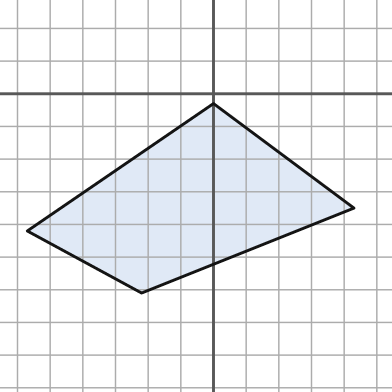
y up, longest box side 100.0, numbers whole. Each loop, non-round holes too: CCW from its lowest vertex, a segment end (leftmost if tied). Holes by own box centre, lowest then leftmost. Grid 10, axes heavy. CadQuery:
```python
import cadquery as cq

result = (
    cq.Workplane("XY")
    .moveTo(-22.0, -61.0)
    .lineTo(43.0, -35.0)
    .lineTo(0.0, -3.0)
    .lineTo(-57.0, -42.0)
    .close()
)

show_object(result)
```